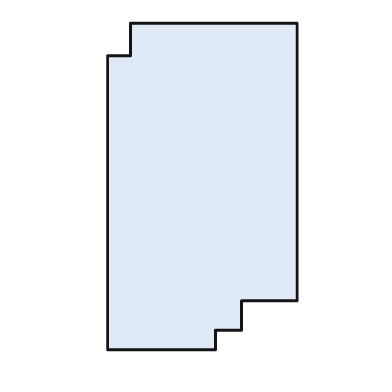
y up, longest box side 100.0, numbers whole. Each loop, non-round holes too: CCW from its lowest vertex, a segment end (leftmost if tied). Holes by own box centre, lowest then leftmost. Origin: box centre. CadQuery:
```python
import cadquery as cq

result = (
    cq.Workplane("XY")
    .moveTo(-29.0, -50.0)
    .lineTo(4.0, -50.0)
    .lineTo(4.0, -44.0)
    .lineTo(12.0, -44.0)
    .lineTo(12.0, -35.0)
    .lineTo(29.0, -35.0)
    .lineTo(29.0, 50.0)
    .lineTo(-22.0, 50.0)
    .lineTo(-22.0, 40.0)
    .lineTo(-29.0, 40.0)
    .close()
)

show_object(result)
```